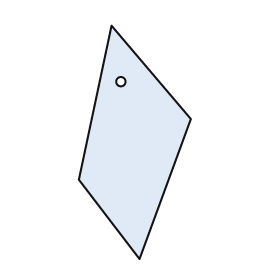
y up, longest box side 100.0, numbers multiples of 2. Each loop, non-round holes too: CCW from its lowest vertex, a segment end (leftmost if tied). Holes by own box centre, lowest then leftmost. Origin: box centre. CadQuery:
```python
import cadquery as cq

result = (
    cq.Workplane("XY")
    .moveTo(2.0, -50.0)
    .lineTo(24.0, 10.0)
    .lineTo(-10.0, 50.0)
    .lineTo(-24.0, -16.0)
    .close()
    .moveTo(-6.0, 26.0)
    .circle(2.0)
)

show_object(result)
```